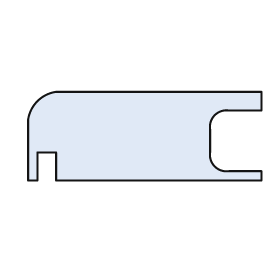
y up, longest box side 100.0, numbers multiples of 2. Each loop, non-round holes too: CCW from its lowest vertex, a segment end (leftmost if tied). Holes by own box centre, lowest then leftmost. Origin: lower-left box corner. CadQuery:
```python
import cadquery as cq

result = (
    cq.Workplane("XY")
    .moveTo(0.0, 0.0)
    .lineTo(4.0, 0.0)
    .lineTo(4.0, 12.0)
    .lineTo(12.0, 12.0)
    .lineTo(12.0, 0.0)
    .lineTo(100.0, 0.0)
    .lineTo(100.0, 4.0)
    .lineTo(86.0, 4.0)
    .threePointArc((80.0, 6.0), (78.0, 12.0))
    .lineTo(78.0, 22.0)
    .threePointArc((80.0, 28.0), (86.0, 30.0))
    .lineTo(100.0, 30.0)
    .lineTo(100.0, 38.0)
    .lineTo(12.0, 38.0)
    .threePointArc((4.0, 34.0), (0.0, 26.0))
    .close()
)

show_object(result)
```